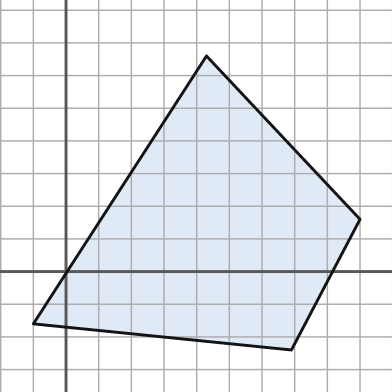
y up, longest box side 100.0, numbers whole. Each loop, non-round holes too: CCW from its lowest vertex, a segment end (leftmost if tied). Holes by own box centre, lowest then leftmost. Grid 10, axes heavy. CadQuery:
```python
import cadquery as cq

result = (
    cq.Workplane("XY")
    .moveTo(69.0, -24.0)
    .lineTo(90.0, 16.0)
    .lineTo(43.0, 66.0)
    .lineTo(-10.0, -16.0)
    .close()
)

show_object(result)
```